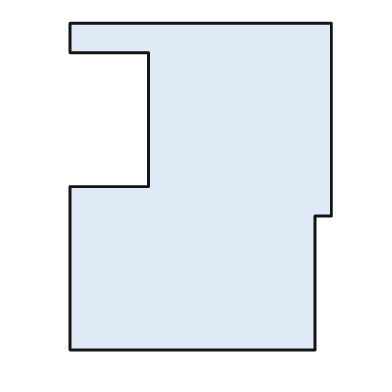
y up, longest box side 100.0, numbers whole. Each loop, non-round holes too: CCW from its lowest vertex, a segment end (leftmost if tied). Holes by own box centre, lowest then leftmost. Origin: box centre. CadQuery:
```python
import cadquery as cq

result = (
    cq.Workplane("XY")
    .moveTo(-40.0, -50.0)
    .lineTo(35.0, -50.0)
    .lineTo(35.0, -9.0)
    .lineTo(40.0, -9.0)
    .lineTo(40.0, 50.0)
    .lineTo(-40.0, 50.0)
    .lineTo(-40.0, 41.0)
    .lineTo(-16.0, 41.0)
    .lineTo(-16.0, 0.0)
    .lineTo(-40.0, 0.0)
    .close()
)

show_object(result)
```